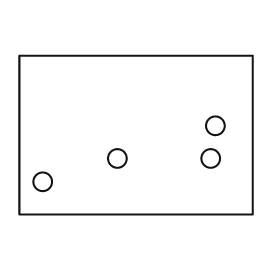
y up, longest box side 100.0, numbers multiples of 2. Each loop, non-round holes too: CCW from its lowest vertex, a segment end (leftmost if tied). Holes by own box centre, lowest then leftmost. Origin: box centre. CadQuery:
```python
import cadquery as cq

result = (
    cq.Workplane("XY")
    .moveTo(-50.0, -34.0)
    .lineTo(50.0, -34.0)
    .lineTo(50.0, 34.0)
    .lineTo(-50.0, 34.0)
    .close()
    .moveTo(-40.0, -20.0)
    .circle(4.0)
    .moveTo(-8.0, -10.0)
    .circle(4.0)
    .moveTo(32.0, -10.0)
    .circle(4.0)
    .moveTo(34.0, 4.0)
    .circle(4.0)
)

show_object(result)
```